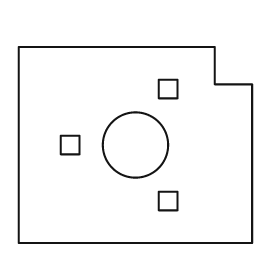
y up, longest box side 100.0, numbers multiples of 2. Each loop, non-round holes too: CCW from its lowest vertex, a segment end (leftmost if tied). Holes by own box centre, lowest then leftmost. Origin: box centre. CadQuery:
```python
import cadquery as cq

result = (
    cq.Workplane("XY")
    .moveTo(-50.0, -42.0)
    .lineTo(50.0, -42.0)
    .lineTo(50.0, 26.0)
    .lineTo(34.0, 26.0)
    .lineTo(34.0, 42.0)
    .lineTo(-50.0, 42.0)
    .close()
    .moveTo(10.0, -28.0)
    .lineTo(18.0, -28.0)
    .lineTo(18.0, -20.0)
    .lineTo(10.0, -20.0)
    .close()
    .moveTo(-32.0, -4.0)
    .lineTo(-24.0, -4.0)
    .lineTo(-24.0, 4.0)
    .lineTo(-32.0, 4.0)
    .close()
    .moveTo(0.0, 0.0)
    .circle(14.0)
    .moveTo(10.0, 20.0)
    .lineTo(18.0, 20.0)
    .lineTo(18.0, 28.0)
    .lineTo(10.0, 28.0)
    .close()
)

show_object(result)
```